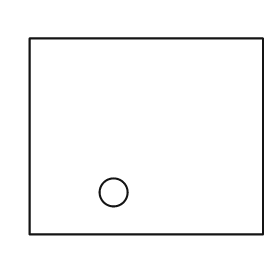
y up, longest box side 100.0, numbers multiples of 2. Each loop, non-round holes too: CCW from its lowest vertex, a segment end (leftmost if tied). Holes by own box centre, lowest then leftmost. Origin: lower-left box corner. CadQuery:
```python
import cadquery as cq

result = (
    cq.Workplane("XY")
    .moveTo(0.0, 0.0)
    .lineTo(100.0, 0.0)
    .lineTo(100.0, 84.0)
    .lineTo(0.0, 84.0)
    .close()
    .moveTo(36.0, 18.0)
    .circle(6.0)
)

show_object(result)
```